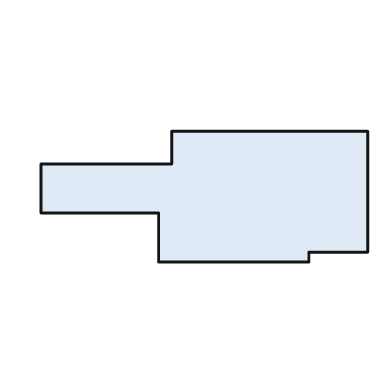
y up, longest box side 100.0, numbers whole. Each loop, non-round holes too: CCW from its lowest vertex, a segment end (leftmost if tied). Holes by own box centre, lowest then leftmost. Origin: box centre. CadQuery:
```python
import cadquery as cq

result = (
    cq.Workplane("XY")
    .moveTo(-14.0, -20.0)
    .lineTo(32.0, -20.0)
    .lineTo(32.0, -17.0)
    .lineTo(50.0, -17.0)
    .lineTo(50.0, 20.0)
    .lineTo(-10.0, 20.0)
    .lineTo(-10.0, 10.0)
    .lineTo(-50.0, 10.0)
    .lineTo(-50.0, -5.0)
    .lineTo(-14.0, -5.0)
    .close()
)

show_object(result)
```